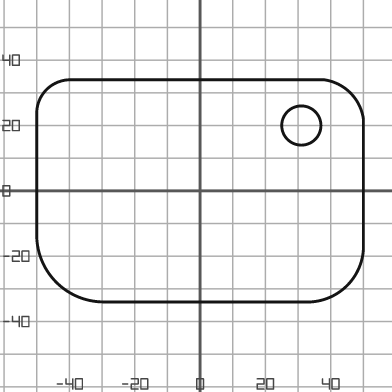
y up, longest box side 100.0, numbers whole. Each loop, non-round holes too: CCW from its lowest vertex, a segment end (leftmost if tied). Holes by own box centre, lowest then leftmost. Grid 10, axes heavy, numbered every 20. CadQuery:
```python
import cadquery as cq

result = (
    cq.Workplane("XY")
    .moveTo(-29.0, -34.0)
    .lineTo(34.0, -34.0)
    .threePointArc((45.0, -29.0), (50.0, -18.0))
    .lineTo(50.0, 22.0)
    .threePointArc((46.0, 30.0), (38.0, 34.0))
    .lineTo(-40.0, 34.0)
    .threePointArc((-47.0, 31.0), (-50.0, 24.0))
    .lineTo(-50.0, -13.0)
    .threePointArc((-44.0, -28.0), (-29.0, -34.0))
    .close()
    .moveTo(31.0, 20.0)
    .circle(6.0)
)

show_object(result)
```